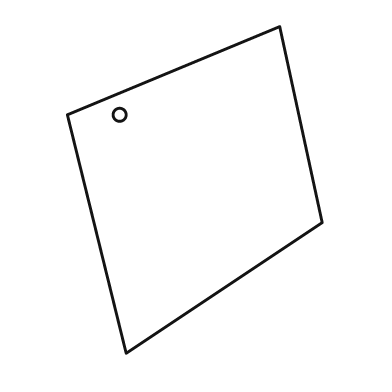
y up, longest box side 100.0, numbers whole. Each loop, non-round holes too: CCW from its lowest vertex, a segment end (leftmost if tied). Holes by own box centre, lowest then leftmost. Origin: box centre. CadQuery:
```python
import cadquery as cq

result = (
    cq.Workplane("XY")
    .moveTo(-21.0, -50.0)
    .lineTo(39.0, -10.0)
    .lineTo(26.0, 50.0)
    .lineTo(-39.0, 23.0)
    .close()
    .moveTo(-23.0, 23.0)
    .circle(2.0)
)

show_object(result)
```